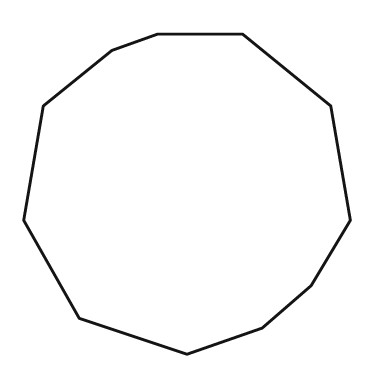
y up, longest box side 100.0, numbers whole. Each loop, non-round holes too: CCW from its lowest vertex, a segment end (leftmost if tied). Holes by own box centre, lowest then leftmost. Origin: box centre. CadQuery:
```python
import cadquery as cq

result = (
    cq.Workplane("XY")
    .moveTo(0.0, -49.0)
    .lineTo(23.0, -41.0)
    .lineTo(38.0, -28.0)
    .lineTo(50.0, -8.0)
    .lineTo(44.0, 27.0)
    .lineTo(17.0, 49.0)
    .lineTo(-9.0, 49.0)
    .lineTo(-23.0, 44.0)
    .lineTo(-44.0, 27.0)
    .lineTo(-50.0, -8.0)
    .lineTo(-33.0, -38.0)
    .close()
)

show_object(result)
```